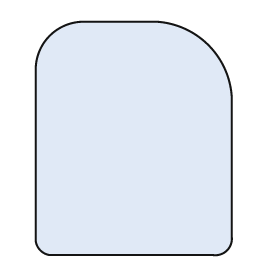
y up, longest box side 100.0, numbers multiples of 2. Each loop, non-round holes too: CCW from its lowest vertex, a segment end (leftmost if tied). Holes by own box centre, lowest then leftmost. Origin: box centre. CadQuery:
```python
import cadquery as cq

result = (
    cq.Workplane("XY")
    .moveTo(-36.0, -50.0)
    .lineTo(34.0, -50.0)
    .threePointArc((40.0, -48.0), (42.0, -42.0))
    .lineTo(42.0, 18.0)
    .threePointArc((32.0, 40.0), (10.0, 50.0))
    .lineTo(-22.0, 50.0)
    .threePointArc((-36.0, 44.0), (-42.0, 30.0))
    .lineTo(-42.0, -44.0)
    .threePointArc((-40.0, -48.0), (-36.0, -50.0))
    .close()
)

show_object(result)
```